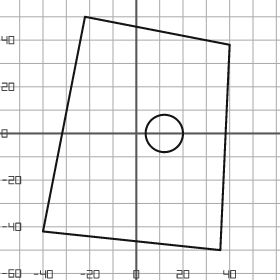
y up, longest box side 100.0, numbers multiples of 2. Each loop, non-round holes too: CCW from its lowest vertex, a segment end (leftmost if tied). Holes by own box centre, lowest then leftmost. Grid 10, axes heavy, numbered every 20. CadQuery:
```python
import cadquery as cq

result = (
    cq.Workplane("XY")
    .moveTo(36.0, -50.0)
    .lineTo(40.0, 38.0)
    .lineTo(-22.0, 50.0)
    .lineTo(-40.0, -42.0)
    .close()
    .moveTo(12.0, 0.0)
    .circle(8.0)
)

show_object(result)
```